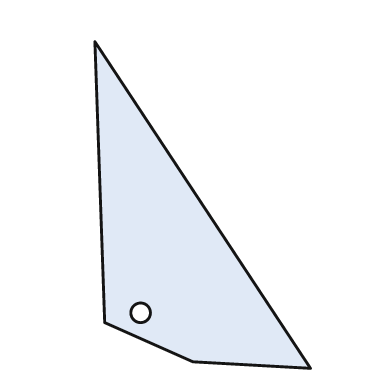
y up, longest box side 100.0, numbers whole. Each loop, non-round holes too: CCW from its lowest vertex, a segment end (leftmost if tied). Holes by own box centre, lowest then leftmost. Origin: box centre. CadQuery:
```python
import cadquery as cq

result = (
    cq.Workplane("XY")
    .moveTo(33.0, -50.0)
    .lineTo(-33.0, 50.0)
    .lineTo(-30.0, -36.0)
    .lineTo(-3.0, -48.0)
    .close()
    .moveTo(-19.0, -33.0)
    .circle(3.0)
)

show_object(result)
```